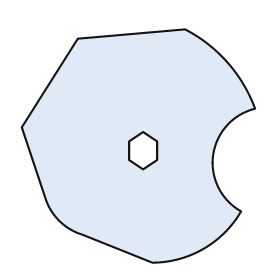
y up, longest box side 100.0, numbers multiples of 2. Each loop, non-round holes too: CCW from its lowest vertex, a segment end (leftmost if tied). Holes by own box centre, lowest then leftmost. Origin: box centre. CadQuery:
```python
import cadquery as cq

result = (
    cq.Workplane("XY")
    .moveTo(6.0, -50.0)
    .threePointArc((28.0, -44.0), (44.0, -28.0))
    .threePointArc((32.0, -4.0), (50.0, 16.0))
    .threePointArc((38.0, 36.0), (20.0, 50.0))
    .lineTo(-26.0, 46.0)
    .lineTo(-50.0, 8.0)
    .lineTo(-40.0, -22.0)
    .threePointArc((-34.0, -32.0), (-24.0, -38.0))
    .close()
    .moveTo(2.0, -10.0)
    .lineTo(8.0, -6.0)
    .lineTo(8.0, 2.0)
    .lineTo(2.0, 6.0)
    .lineTo(-4.0, 2.0)
    .lineTo(-4.0, -6.0)
    .close()
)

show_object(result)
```